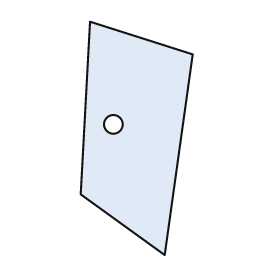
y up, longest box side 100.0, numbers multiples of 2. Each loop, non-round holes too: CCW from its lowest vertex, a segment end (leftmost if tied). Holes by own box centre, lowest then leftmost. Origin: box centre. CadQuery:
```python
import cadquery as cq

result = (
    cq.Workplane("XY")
    .moveTo(12.0, -50.0)
    .lineTo(24.0, 36.0)
    .lineTo(-20.0, 50.0)
    .lineTo(-24.0, -24.0)
    .close()
    .moveTo(-10.0, 6.0)
    .circle(4.0)
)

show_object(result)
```